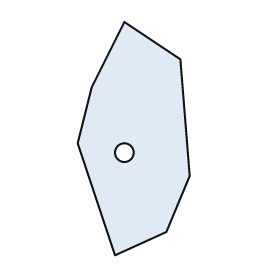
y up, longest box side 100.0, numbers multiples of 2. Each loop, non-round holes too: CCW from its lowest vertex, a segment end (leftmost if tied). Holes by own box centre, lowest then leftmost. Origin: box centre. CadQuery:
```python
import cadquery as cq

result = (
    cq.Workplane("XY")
    .moveTo(-8.0, -50.0)
    .lineTo(14.0, -40.0)
    .lineTo(24.0, -16.0)
    .lineTo(20.0, 34.0)
    .lineTo(-4.0, 50.0)
    .lineTo(-18.0, 22.0)
    .lineTo(-24.0, -2.0)
    .close()
    .moveTo(-4.0, -6.0)
    .circle(4.0)
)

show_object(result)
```